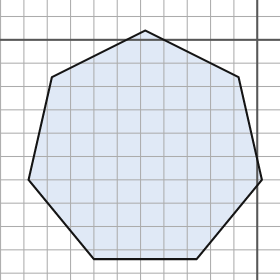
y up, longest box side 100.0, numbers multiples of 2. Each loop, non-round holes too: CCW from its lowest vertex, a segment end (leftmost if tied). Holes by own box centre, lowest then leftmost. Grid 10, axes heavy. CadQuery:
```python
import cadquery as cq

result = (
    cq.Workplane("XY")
    .moveTo(-70.0, -94.0)
    .lineTo(-26.0, -94.0)
    .lineTo(2.0, -60.0)
    .lineTo(-8.0, -16.0)
    .lineTo(-48.0, 4.0)
    .lineTo(-88.0, -16.0)
    .lineTo(-98.0, -60.0)
    .close()
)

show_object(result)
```